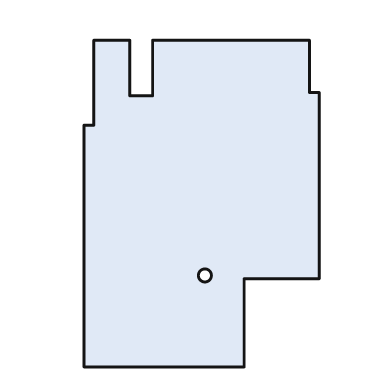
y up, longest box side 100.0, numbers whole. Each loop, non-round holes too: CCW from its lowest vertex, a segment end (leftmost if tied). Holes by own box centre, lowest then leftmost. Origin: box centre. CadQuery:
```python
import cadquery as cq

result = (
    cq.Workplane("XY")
    .moveTo(-36.0, -50.0)
    .lineTo(13.0, -50.0)
    .lineTo(13.0, -23.0)
    .lineTo(36.0, -23.0)
    .lineTo(36.0, 34.0)
    .lineTo(33.0, 34.0)
    .lineTo(33.0, 50.0)
    .lineTo(-15.0, 50.0)
    .lineTo(-15.0, 33.0)
    .lineTo(-22.0, 33.0)
    .lineTo(-22.0, 50.0)
    .lineTo(-33.0, 50.0)
    .lineTo(-33.0, 24.0)
    .lineTo(-36.0, 24.0)
    .close()
    .moveTo(1.0, -22.0)
    .circle(2.0)
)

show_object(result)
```